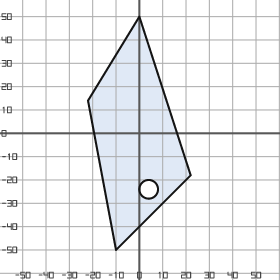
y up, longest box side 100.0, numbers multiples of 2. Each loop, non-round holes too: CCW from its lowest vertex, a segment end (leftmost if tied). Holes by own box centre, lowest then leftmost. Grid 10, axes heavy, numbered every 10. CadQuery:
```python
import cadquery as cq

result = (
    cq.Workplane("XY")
    .moveTo(-10.0, -50.0)
    .lineTo(22.0, -18.0)
    .lineTo(0.0, 50.0)
    .lineTo(-22.0, 14.0)
    .close()
    .moveTo(4.0, -24.0)
    .circle(4.0)
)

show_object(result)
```